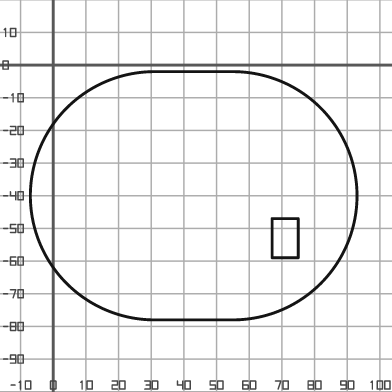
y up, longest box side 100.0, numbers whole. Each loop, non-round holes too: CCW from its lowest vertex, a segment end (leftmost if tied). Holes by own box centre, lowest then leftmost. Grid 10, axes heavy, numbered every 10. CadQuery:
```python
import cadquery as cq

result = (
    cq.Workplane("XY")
    .moveTo(31.0, -78.0)
    .lineTo(55.0, -78.0)
    .threePointArc((93.0, -40.0), (55.0, -2.0))
    .lineTo(31.0, -2.0)
    .threePointArc((-7.0, -40.0), (31.0, -78.0))
    .close()
    .moveTo(67.0, -59.0)
    .lineTo(75.0, -59.0)
    .lineTo(75.0, -47.0)
    .lineTo(67.0, -47.0)
    .close()
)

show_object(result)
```